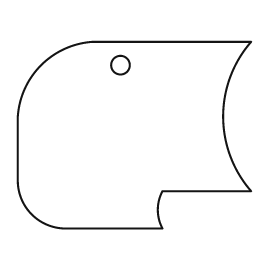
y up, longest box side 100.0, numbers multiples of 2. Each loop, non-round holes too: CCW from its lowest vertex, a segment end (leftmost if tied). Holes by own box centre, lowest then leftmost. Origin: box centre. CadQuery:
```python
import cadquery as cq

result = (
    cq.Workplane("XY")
    .moveTo(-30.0, -40.0)
    .lineTo(12.0, -40.0)
    .threePointArc((10.0, -32.0), (12.0, -24.0))
    .lineTo(50.0, -24.0)
    .threePointArc((38.0, 8.0), (50.0, 40.0))
    .lineTo(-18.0, 40.0)
    .threePointArc((-40.0, 30.0), (-50.0, 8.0))
    .lineTo(-50.0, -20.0)
    .threePointArc((-44.0, -34.0), (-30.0, -40.0))
    .close()
    .moveTo(-6.0, 30.0)
    .circle(4.0)
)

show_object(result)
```